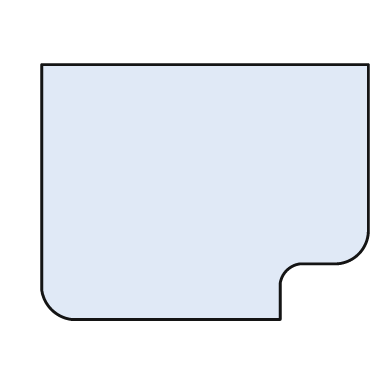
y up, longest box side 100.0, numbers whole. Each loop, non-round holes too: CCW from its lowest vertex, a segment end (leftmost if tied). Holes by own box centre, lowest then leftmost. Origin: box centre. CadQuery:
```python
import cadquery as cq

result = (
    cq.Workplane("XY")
    .moveTo(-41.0, -39.0)
    .lineTo(23.0, -39.0)
    .lineTo(23.0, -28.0)
    .threePointArc((25.0, -24.0), (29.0, -22.0))
    .lineTo(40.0, -22.0)
    .threePointArc((47.0, -19.0), (50.0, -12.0))
    .lineTo(50.0, 39.0)
    .lineTo(-50.0, 39.0)
    .lineTo(-50.0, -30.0)
    .threePointArc((-47.0, -36.0), (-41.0, -39.0))
    .close()
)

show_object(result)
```